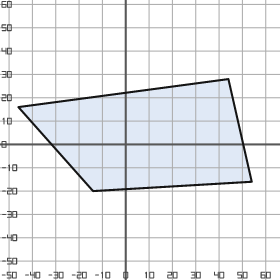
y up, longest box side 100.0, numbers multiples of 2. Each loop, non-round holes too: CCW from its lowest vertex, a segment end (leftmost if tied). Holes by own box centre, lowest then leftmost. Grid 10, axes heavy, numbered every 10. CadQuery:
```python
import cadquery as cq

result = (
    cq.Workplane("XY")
    .moveTo(-14.0, -20.0)
    .lineTo(54.0, -16.0)
    .lineTo(44.0, 28.0)
    .lineTo(-46.0, 16.0)
    .close()
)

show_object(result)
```